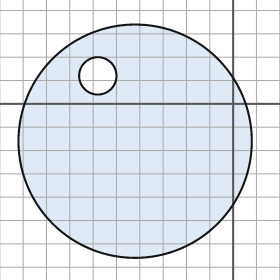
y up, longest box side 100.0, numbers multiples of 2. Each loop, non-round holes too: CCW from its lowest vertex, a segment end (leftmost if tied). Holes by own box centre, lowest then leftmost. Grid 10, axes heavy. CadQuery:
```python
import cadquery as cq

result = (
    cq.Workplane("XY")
    .moveTo(-42.0, -16.0)
    .circle(50.0)
    .moveTo(-58.0, 12.0)
    .circle(8.0)
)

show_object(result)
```